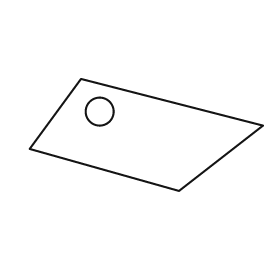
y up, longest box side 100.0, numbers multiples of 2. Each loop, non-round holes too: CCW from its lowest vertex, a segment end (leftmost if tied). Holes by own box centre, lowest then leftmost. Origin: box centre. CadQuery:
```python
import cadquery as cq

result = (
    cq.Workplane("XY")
    .moveTo(14.0, -24.0)
    .lineTo(50.0, 4.0)
    .lineTo(-28.0, 24.0)
    .lineTo(-50.0, -6.0)
    .close()
    .moveTo(-20.0, 10.0)
    .circle(6.0)
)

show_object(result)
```